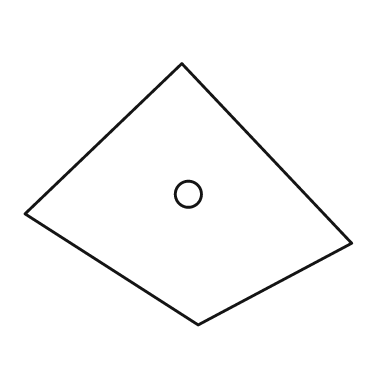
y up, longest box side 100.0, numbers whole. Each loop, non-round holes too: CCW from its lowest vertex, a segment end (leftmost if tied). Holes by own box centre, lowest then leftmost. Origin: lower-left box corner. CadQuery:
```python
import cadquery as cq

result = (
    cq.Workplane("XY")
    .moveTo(53.0, 0.0)
    .lineTo(100.0, 25.0)
    .lineTo(48.0, 80.0)
    .lineTo(0.0, 34.0)
    .close()
    .moveTo(50.0, 40.0)
    .circle(4.0)
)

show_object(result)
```